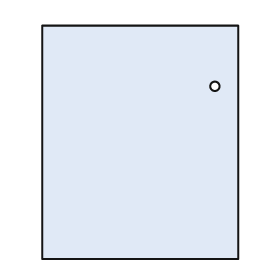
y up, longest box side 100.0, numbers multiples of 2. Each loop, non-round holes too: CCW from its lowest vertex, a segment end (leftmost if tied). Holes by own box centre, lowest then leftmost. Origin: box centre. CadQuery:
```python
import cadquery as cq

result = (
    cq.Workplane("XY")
    .moveTo(-42.0, -50.0)
    .lineTo(42.0, -50.0)
    .lineTo(42.0, 50.0)
    .lineTo(-42.0, 50.0)
    .close()
    .moveTo(32.0, 24.0)
    .circle(2.0)
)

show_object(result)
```